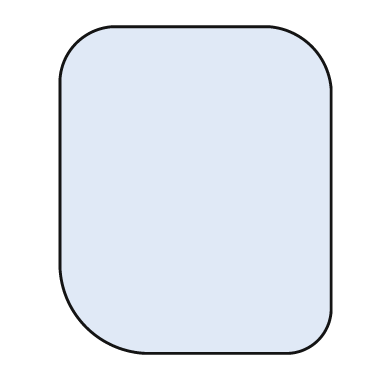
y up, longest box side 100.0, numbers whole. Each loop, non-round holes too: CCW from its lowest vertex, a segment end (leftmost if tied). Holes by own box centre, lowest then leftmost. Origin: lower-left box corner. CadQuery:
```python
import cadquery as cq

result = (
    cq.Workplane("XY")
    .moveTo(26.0, 0.0)
    .lineTo(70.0, 0.0)
    .threePointArc((79.0, 4.0), (83.0, 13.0))
    .lineTo(83.0, 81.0)
    .threePointArc((77.0, 94.0), (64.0, 100.0))
    .lineTo(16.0, 100.0)
    .threePointArc((5.0, 95.0), (0.0, 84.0))
    .lineTo(0.0, 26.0)
    .threePointArc((8.0, 8.0), (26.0, 0.0))
    .close()
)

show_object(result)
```